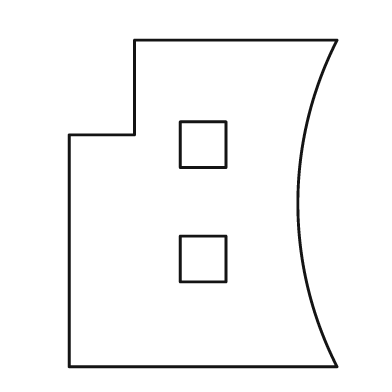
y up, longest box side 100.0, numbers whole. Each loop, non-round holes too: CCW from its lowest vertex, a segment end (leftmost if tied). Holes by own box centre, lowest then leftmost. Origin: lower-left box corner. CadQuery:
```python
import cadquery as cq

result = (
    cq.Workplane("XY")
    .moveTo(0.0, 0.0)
    .lineTo(82.0, 0.0)
    .threePointArc((70.0, 50.0), (82.0, 100.0))
    .lineTo(20.0, 100.0)
    .lineTo(20.0, 71.0)
    .lineTo(0.0, 71.0)
    .close()
    .moveTo(34.0, 26.0)
    .lineTo(48.0, 26.0)
    .lineTo(48.0, 40.0)
    .lineTo(34.0, 40.0)
    .close()
    .moveTo(34.0, 61.0)
    .lineTo(48.0, 61.0)
    .lineTo(48.0, 75.0)
    .lineTo(34.0, 75.0)
    .close()
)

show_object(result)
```